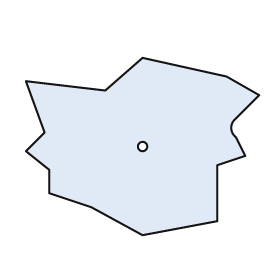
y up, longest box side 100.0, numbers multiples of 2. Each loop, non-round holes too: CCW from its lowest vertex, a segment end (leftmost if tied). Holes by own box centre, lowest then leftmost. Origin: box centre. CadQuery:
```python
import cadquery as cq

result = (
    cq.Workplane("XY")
    .moveTo(0.0, -38.0)
    .lineTo(32.0, -32.0)
    .lineTo(32.0, -8.0)
    .lineTo(44.0, -4.0)
    .lineTo(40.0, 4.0)
    .threePointArc((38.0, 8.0), (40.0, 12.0))
    .lineTo(50.0, 22.0)
    .lineTo(36.0, 30.0)
    .lineTo(0.0, 38.0)
    .lineTo(-16.0, 24.0)
    .lineTo(-50.0, 28.0)
    .lineTo(-42.0, 6.0)
    .lineTo(-50.0, -2.0)
    .lineTo(-40.0, -10.0)
    .lineTo(-40.0, -20.0)
    .lineTo(-22.0, -26.0)
    .close()
    .moveTo(0.0, 0.0)
    .circle(2.0)
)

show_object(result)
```